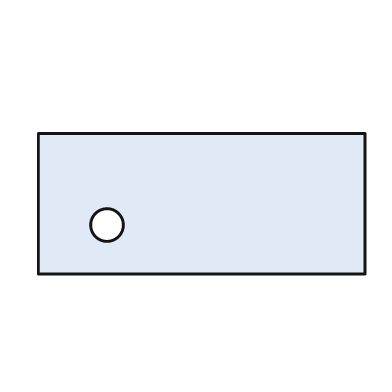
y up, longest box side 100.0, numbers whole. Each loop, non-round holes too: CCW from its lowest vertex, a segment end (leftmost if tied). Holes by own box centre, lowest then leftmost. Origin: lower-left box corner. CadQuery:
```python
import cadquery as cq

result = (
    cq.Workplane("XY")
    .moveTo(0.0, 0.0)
    .lineTo(100.0, 0.0)
    .lineTo(100.0, 43.0)
    .lineTo(0.0, 43.0)
    .close()
    .moveTo(21.0, 15.0)
    .circle(5.0)
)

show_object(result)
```